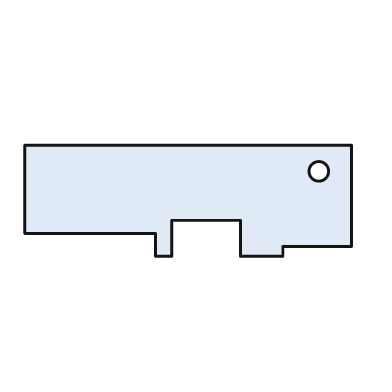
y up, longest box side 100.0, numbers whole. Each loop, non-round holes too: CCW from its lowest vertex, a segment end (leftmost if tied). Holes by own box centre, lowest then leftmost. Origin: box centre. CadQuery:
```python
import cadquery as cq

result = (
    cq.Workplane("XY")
    .moveTo(-10.0, -17.0)
    .lineTo(-5.0, -17.0)
    .lineTo(-5.0, -6.0)
    .lineTo(16.0, -6.0)
    .lineTo(16.0, -17.0)
    .lineTo(29.0, -17.0)
    .lineTo(29.0, -14.0)
    .lineTo(50.0, -14.0)
    .lineTo(50.0, 17.0)
    .lineTo(-50.0, 17.0)
    .lineTo(-50.0, -10.0)
    .lineTo(-10.0, -10.0)
    .close()
    .moveTo(40.0, 9.0)
    .circle(3.0)
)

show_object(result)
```